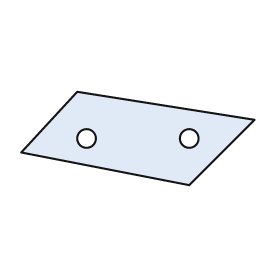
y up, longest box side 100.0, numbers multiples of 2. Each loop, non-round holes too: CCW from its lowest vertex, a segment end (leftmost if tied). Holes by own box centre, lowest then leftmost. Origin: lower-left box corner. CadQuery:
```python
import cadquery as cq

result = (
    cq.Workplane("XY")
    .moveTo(72.0, 0.0)
    .lineTo(100.0, 28.0)
    .lineTo(24.0, 40.0)
    .lineTo(0.0, 14.0)
    .close()
    .moveTo(28.0, 20.0)
    .circle(4.0)
    .moveTo(72.0, 20.0)
    .circle(4.0)
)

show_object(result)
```